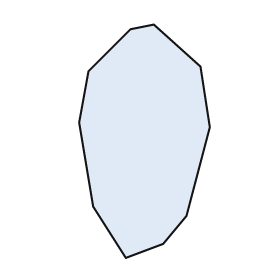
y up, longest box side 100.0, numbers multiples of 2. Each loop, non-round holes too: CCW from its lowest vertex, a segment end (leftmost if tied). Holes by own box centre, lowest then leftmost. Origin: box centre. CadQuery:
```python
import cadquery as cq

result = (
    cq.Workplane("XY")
    .moveTo(-8.0, -50.0)
    .lineTo(8.0, -44.0)
    .lineTo(18.0, -32.0)
    .lineTo(28.0, 6.0)
    .lineTo(24.0, 32.0)
    .lineTo(4.0, 50.0)
    .lineTo(-6.0, 48.0)
    .lineTo(-24.0, 30.0)
    .lineTo(-28.0, 8.0)
    .lineTo(-22.0, -28.0)
    .close()
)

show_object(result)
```